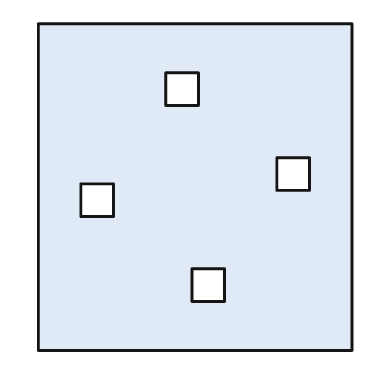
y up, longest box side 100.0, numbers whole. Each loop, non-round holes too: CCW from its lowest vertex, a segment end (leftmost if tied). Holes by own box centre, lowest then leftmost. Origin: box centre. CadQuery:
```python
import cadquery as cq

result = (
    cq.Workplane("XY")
    .moveTo(-48.0, -50.0)
    .lineTo(48.0, -50.0)
    .lineTo(48.0, 50.0)
    .lineTo(-48.0, 50.0)
    .close()
    .moveTo(-1.0, -35.0)
    .lineTo(9.0, -35.0)
    .lineTo(9.0, -25.0)
    .lineTo(-1.0, -25.0)
    .close()
    .moveTo(-35.0, -9.0)
    .lineTo(-25.0, -9.0)
    .lineTo(-25.0, 1.0)
    .lineTo(-35.0, 1.0)
    .close()
    .moveTo(25.0, -1.0)
    .lineTo(35.0, -1.0)
    .lineTo(35.0, 9.0)
    .lineTo(25.0, 9.0)
    .close()
    .moveTo(-9.0, 25.0)
    .lineTo(1.0, 25.0)
    .lineTo(1.0, 35.0)
    .lineTo(-9.0, 35.0)
    .close()
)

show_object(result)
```